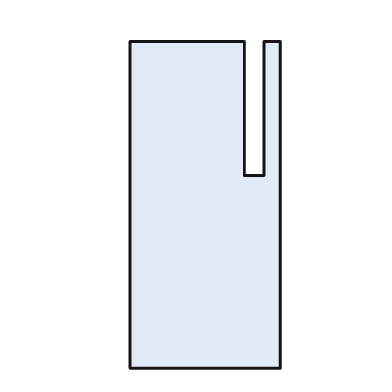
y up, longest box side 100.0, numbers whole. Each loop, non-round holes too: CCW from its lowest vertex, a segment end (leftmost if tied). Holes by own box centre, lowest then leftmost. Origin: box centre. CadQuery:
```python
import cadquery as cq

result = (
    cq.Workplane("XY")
    .moveTo(-23.0, -50.0)
    .lineTo(23.0, -50.0)
    .lineTo(23.0, 50.0)
    .lineTo(18.0, 50.0)
    .lineTo(18.0, 9.0)
    .lineTo(12.0, 9.0)
    .lineTo(12.0, 50.0)
    .lineTo(-23.0, 50.0)
    .close()
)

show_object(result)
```